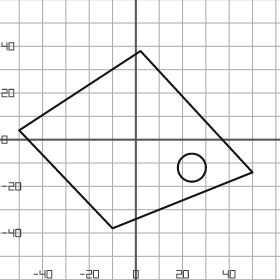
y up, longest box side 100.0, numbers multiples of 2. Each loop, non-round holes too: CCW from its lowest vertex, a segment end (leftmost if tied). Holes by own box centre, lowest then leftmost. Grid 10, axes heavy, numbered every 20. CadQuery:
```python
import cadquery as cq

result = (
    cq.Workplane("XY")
    .moveTo(-10.0, -38.0)
    .lineTo(50.0, -14.0)
    .lineTo(2.0, 38.0)
    .lineTo(-50.0, 4.0)
    .close()
    .moveTo(24.0, -12.0)
    .circle(6.0)
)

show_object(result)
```